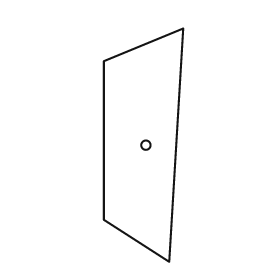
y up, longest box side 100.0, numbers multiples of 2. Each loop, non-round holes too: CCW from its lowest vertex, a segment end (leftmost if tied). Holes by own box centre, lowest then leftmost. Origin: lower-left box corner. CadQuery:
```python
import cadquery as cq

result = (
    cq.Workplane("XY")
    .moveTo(28.0, 0.0)
    .lineTo(34.0, 100.0)
    .lineTo(0.0, 86.0)
    .lineTo(0.0, 18.0)
    .close()
    .moveTo(18.0, 50.0)
    .circle(2.0)
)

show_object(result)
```